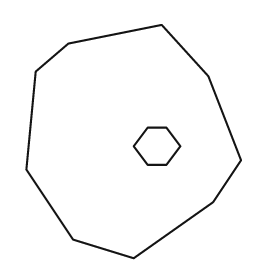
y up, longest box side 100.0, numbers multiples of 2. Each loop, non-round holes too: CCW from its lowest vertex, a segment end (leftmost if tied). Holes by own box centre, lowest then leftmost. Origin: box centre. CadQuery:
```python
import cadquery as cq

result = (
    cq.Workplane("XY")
    .moveTo(0.0, -50.0)
    .lineTo(34.0, -26.0)
    .lineTo(46.0, -8.0)
    .lineTo(32.0, 28.0)
    .lineTo(12.0, 50.0)
    .lineTo(-28.0, 42.0)
    .lineTo(-42.0, 30.0)
    .lineTo(-46.0, -12.0)
    .lineTo(-26.0, -42.0)
    .close()
    .moveTo(6.0, -10.0)
    .lineTo(14.0, -10.0)
    .lineTo(20.0, -2.0)
    .lineTo(14.0, 6.0)
    .lineTo(6.0, 6.0)
    .lineTo(0.0, -2.0)
    .close()
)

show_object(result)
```